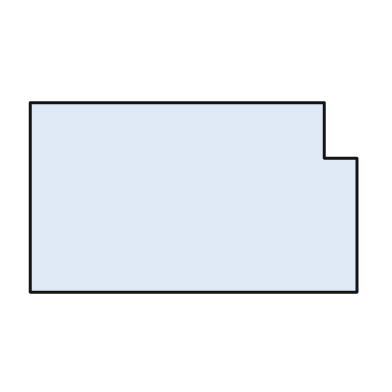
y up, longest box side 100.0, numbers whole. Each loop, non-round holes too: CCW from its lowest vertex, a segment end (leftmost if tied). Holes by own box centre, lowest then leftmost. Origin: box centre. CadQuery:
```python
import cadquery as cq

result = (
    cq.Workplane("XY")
    .moveTo(-50.0, -29.0)
    .lineTo(50.0, -29.0)
    .lineTo(50.0, 12.0)
    .lineTo(40.0, 12.0)
    .lineTo(40.0, 29.0)
    .lineTo(-50.0, 29.0)
    .close()
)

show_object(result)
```